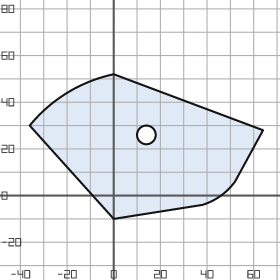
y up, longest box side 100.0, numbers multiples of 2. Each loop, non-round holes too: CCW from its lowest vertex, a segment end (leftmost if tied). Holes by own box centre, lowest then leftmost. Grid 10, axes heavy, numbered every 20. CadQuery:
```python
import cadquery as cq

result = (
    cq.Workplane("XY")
    .moveTo(0.0, -10.0)
    .lineTo(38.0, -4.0)
    .threePointArc((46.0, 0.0), (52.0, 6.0))
    .lineTo(64.0, 28.0)
    .lineTo(0.0, 52.0)
    .threePointArc((-20.0, 44.0), (-36.0, 30.0))
    .close()
    .moveTo(14.0, 26.0)
    .circle(4.0)
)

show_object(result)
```